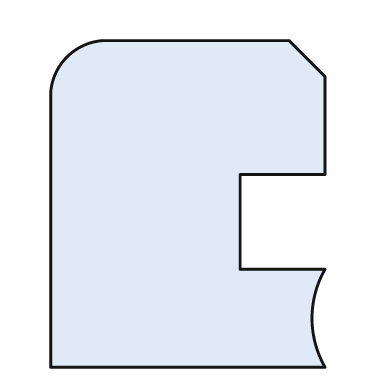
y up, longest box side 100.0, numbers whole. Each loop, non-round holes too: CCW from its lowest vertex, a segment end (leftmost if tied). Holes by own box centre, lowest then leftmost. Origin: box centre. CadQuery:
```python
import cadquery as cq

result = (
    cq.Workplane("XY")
    .moveTo(-42.0, -50.0)
    .lineTo(42.0, -50.0)
    .threePointArc((38.0, -35.0), (42.0, -20.0))
    .lineTo(16.0, -20.0)
    .lineTo(16.0, 9.0)
    .lineTo(42.0, 9.0)
    .lineTo(42.0, 39.0)
    .lineTo(31.0, 50.0)
    .lineTo(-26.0, 50.0)
    .threePointArc((-37.0, 45.0), (-42.0, 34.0))
    .close()
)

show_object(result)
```